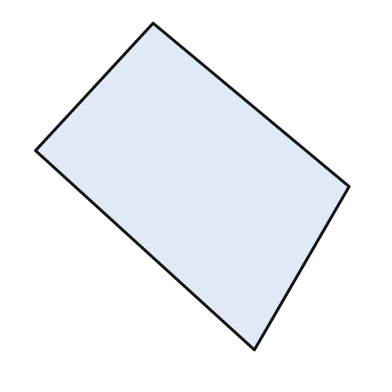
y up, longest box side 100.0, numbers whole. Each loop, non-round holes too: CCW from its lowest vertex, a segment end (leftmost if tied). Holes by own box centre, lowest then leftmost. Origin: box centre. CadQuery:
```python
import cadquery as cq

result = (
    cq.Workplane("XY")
    .moveTo(19.0, -50.0)
    .lineTo(48.0, 0.0)
    .lineTo(-12.0, 50.0)
    .lineTo(-48.0, 11.0)
    .close()
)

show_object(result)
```